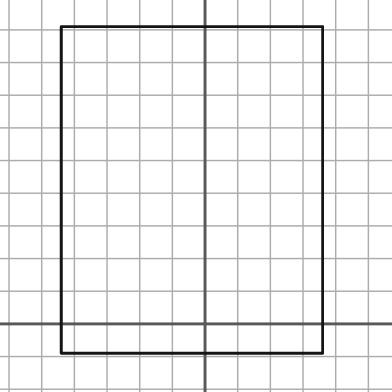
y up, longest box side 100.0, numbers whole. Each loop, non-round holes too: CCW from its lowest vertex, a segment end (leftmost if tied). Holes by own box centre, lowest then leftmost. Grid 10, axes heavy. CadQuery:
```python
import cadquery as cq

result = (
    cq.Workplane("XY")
    .moveTo(-44.0, -9.0)
    .lineTo(36.0, -9.0)
    .lineTo(36.0, 91.0)
    .lineTo(-44.0, 91.0)
    .close()
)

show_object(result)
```